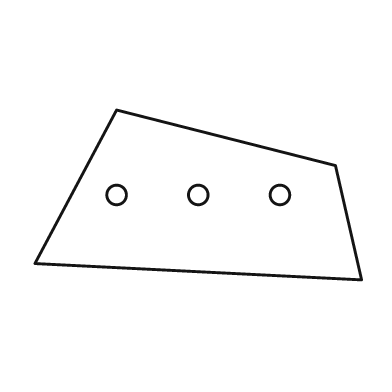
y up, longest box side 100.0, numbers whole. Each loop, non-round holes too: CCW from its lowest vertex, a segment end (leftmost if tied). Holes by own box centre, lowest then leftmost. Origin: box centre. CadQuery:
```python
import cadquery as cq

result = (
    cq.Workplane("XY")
    .moveTo(50.0, -26.0)
    .lineTo(42.0, 9.0)
    .lineTo(-25.0, 26.0)
    .lineTo(-50.0, -21.0)
    .close()
    .moveTo(-25.0, 0.0)
    .circle(3.0)
    .moveTo(0.0, 0.0)
    .circle(3.0)
    .moveTo(25.0, 0.0)
    .circle(3.0)
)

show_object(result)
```